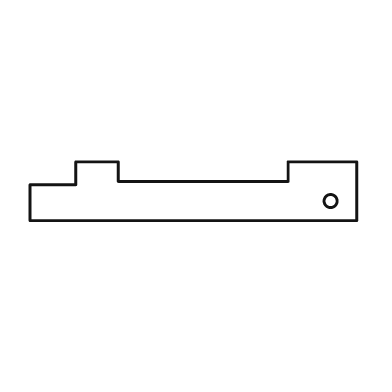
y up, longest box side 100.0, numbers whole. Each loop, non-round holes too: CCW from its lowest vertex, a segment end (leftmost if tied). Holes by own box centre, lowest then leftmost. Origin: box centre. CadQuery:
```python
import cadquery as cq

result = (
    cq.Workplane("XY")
    .moveTo(-50.0, -9.0)
    .lineTo(50.0, -9.0)
    .lineTo(50.0, 9.0)
    .lineTo(29.0, 9.0)
    .lineTo(29.0, 3.0)
    .lineTo(-23.0, 3.0)
    .lineTo(-23.0, 9.0)
    .lineTo(-36.0, 9.0)
    .lineTo(-36.0, 2.0)
    .lineTo(-50.0, 2.0)
    .close()
    .moveTo(42.0, -3.0)
    .circle(2.0)
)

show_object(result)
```